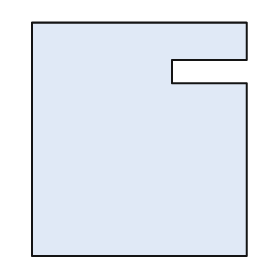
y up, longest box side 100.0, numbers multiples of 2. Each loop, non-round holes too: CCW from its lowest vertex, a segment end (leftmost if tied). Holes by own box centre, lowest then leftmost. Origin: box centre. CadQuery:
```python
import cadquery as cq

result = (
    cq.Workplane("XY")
    .moveTo(-46.0, -50.0)
    .lineTo(46.0, -50.0)
    .lineTo(46.0, 24.0)
    .lineTo(14.0, 24.0)
    .lineTo(14.0, 34.0)
    .lineTo(46.0, 34.0)
    .lineTo(46.0, 50.0)
    .lineTo(-46.0, 50.0)
    .close()
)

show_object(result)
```